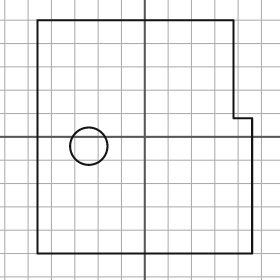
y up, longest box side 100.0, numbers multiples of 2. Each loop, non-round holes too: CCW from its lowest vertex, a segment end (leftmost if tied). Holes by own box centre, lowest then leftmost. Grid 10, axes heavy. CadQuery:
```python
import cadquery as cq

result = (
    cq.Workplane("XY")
    .moveTo(-46.0, -50.0)
    .lineTo(46.0, -50.0)
    .lineTo(46.0, 8.0)
    .lineTo(38.0, 8.0)
    .lineTo(38.0, 50.0)
    .lineTo(-46.0, 50.0)
    .close()
    .moveTo(-24.0, -4.0)
    .circle(8.0)
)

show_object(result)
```